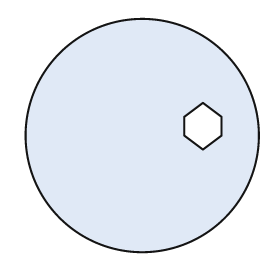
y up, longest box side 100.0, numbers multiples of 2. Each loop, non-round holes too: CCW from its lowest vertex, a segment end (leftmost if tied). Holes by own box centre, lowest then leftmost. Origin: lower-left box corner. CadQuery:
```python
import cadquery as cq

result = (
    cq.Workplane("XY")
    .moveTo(50.0, 50.0)
    .circle(50.0)
    .moveTo(76.0, 44.0)
    .lineTo(84.0, 50.0)
    .lineTo(84.0, 58.0)
    .lineTo(76.0, 64.0)
    .lineTo(68.0, 58.0)
    .lineTo(68.0, 50.0)
    .close()
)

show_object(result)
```